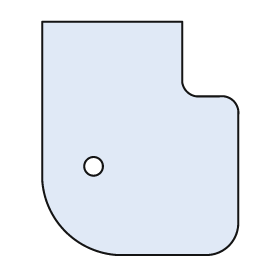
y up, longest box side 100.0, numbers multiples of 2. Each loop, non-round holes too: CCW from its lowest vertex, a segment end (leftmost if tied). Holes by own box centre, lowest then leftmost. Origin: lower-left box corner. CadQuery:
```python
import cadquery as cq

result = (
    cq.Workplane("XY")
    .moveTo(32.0, 0.0)
    .lineTo(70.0, 0.0)
    .threePointArc((80.0, 4.0), (84.0, 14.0))
    .lineTo(84.0, 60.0)
    .threePointArc((82.0, 66.0), (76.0, 68.0))
    .lineTo(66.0, 68.0)
    .threePointArc((62.0, 70.0), (60.0, 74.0))
    .lineTo(60.0, 100.0)
    .lineTo(0.0, 100.0)
    .lineTo(0.0, 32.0)
    .threePointArc((10.0, 10.0), (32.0, 0.0))
    .close()
    .moveTo(22.0, 38.0)
    .circle(4.0)
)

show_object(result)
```